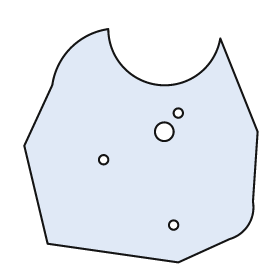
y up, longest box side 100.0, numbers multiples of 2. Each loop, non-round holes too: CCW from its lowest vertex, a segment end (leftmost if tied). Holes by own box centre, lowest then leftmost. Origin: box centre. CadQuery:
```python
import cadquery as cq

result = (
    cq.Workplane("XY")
    .moveTo(16.0, -50.0)
    .lineTo(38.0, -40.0)
    .threePointArc((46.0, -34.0), (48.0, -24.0))
    .lineTo(50.0, 6.0)
    .lineTo(34.0, 46.0)
    .threePointArc((8.0, 26.0), (-14.0, 50.0))
    .threePointArc((-30.0, 42.0), (-38.0, 26.0))
    .lineTo(-50.0, 0.0)
    .lineTo(-40.0, -42.0)
    .close()
    .moveTo(14.0, -34.0)
    .circle(2.0)
    .moveTo(-16.0, -6.0)
    .circle(2.0)
    .moveTo(10.0, 6.0)
    .circle(4.0)
    .moveTo(16.0, 14.0)
    .circle(2.0)
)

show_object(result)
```